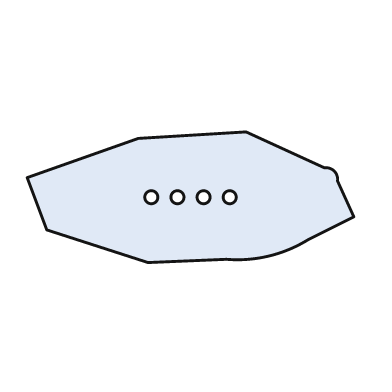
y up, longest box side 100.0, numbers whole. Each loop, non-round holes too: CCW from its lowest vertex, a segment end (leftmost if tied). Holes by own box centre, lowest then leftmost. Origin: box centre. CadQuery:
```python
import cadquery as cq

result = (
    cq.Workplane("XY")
    .moveTo(-13.0, -20.0)
    .lineTo(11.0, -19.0)
    .threePointArc((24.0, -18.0), (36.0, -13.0))
    .lineTo(50.0, -6.0)
    .lineTo(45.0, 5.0)
    .threePointArc((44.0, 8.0), (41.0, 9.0))
    .lineTo(17.0, 20.0)
    .lineTo(-16.0, 18.0)
    .lineTo(-50.0, 6.0)
    .lineTo(-44.0, -10.0)
    .close()
    .moveTo(-12.0, 0.0)
    .circle(2.0)
    .moveTo(-4.0, 0.0)
    .circle(2.0)
    .moveTo(4.0, 0.0)
    .circle(2.0)
    .moveTo(12.0, 0.0)
    .circle(2.0)
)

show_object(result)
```